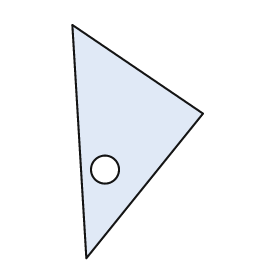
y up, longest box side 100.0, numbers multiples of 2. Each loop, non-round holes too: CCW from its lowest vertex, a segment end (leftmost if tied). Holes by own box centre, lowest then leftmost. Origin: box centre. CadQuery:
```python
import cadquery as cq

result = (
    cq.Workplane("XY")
    .moveTo(-22.0, -50.0)
    .lineTo(28.0, 12.0)
    .lineTo(-28.0, 50.0)
    .close()
    .moveTo(-14.0, -12.0)
    .circle(6.0)
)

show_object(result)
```